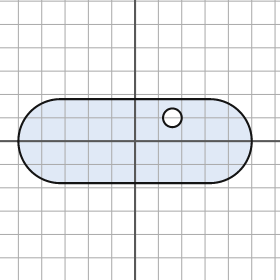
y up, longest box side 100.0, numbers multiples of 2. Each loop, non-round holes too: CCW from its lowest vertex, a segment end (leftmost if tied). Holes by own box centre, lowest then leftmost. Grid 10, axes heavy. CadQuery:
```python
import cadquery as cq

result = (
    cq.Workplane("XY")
    .moveTo(-32.0, -18.0)
    .lineTo(32.0, -18.0)
    .threePointArc((50.0, 0.0), (32.0, 18.0))
    .lineTo(-32.0, 18.0)
    .threePointArc((-50.0, 0.0), (-32.0, -18.0))
    .close()
    .moveTo(16.0, 10.0)
    .circle(4.0)
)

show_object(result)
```